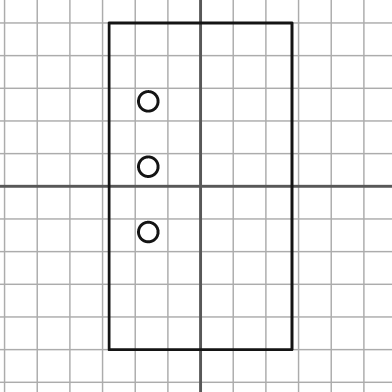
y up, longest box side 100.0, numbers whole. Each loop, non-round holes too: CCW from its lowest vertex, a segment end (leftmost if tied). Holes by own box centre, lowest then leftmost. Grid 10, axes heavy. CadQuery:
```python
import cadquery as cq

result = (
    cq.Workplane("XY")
    .moveTo(-28.0, -50.0)
    .lineTo(28.0, -50.0)
    .lineTo(28.0, 50.0)
    .lineTo(-28.0, 50.0)
    .close()
    .moveTo(-16.0, -14.0)
    .circle(3.0)
    .moveTo(-16.0, 6.0)
    .circle(3.0)
    .moveTo(-16.0, 26.0)
    .circle(3.0)
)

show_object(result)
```